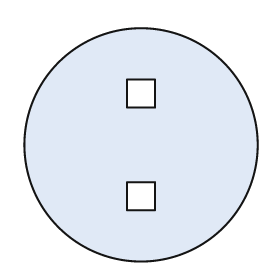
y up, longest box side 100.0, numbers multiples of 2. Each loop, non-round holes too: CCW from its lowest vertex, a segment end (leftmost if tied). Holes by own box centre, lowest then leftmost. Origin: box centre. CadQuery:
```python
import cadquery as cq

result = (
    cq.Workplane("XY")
    .moveTo(0.0, 0.0)
    .circle(50.0)
    .moveTo(-6.0, -28.0)
    .lineTo(6.0, -28.0)
    .lineTo(6.0, -16.0)
    .lineTo(-6.0, -16.0)
    .close()
    .moveTo(-6.0, 16.0)
    .lineTo(6.0, 16.0)
    .lineTo(6.0, 28.0)
    .lineTo(-6.0, 28.0)
    .close()
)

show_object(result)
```